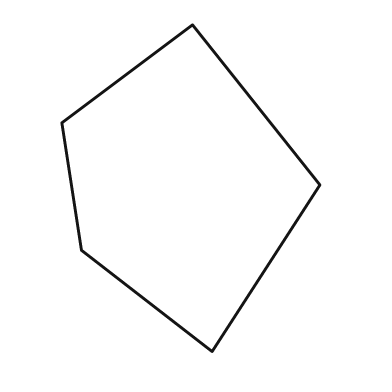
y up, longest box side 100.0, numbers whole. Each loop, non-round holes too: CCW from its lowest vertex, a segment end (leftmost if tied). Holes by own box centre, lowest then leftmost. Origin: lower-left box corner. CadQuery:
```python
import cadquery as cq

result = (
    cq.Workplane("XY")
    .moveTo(46.0, 0.0)
    .lineTo(79.0, 51.0)
    .lineTo(40.0, 100.0)
    .lineTo(0.0, 70.0)
    .lineTo(6.0, 31.0)
    .close()
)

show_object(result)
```